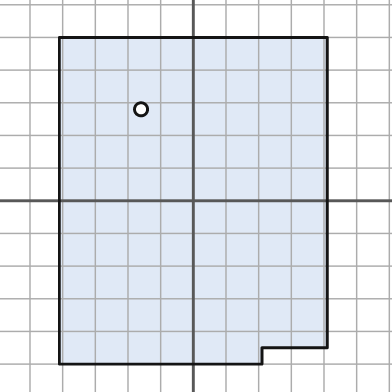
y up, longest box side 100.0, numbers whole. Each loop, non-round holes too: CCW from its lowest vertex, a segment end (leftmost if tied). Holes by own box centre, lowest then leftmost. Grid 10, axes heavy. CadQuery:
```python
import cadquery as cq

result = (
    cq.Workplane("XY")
    .moveTo(-41.0, -50.0)
    .lineTo(21.0, -50.0)
    .lineTo(21.0, -45.0)
    .lineTo(41.0, -45.0)
    .lineTo(41.0, 50.0)
    .lineTo(-41.0, 50.0)
    .close()
    .moveTo(-16.0, 28.0)
    .circle(2.0)
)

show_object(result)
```